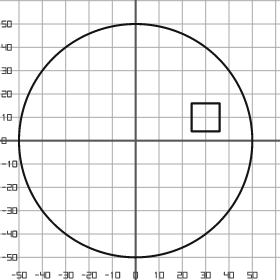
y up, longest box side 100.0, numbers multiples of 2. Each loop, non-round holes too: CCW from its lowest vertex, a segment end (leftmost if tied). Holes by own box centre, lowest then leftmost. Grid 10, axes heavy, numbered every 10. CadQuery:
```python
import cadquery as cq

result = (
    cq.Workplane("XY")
    .moveTo(0.0, 0.0)
    .circle(50.0)
    .moveTo(24.0, 4.0)
    .lineTo(36.0, 4.0)
    .lineTo(36.0, 16.0)
    .lineTo(24.0, 16.0)
    .close()
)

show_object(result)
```